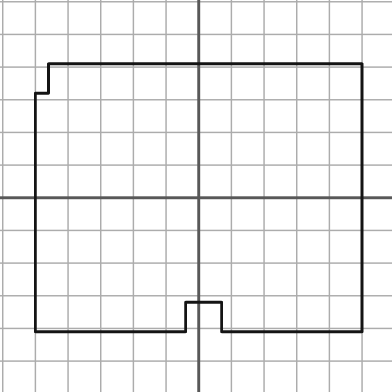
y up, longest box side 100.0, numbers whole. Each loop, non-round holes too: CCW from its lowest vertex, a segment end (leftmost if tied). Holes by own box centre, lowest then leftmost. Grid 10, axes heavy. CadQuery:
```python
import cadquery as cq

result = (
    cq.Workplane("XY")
    .moveTo(-50.0, -41.0)
    .lineTo(-4.0, -41.0)
    .lineTo(-4.0, -32.0)
    .lineTo(7.0, -32.0)
    .lineTo(7.0, -41.0)
    .lineTo(50.0, -41.0)
    .lineTo(50.0, 41.0)
    .lineTo(-46.0, 41.0)
    .lineTo(-46.0, 32.0)
    .lineTo(-50.0, 32.0)
    .close()
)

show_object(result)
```